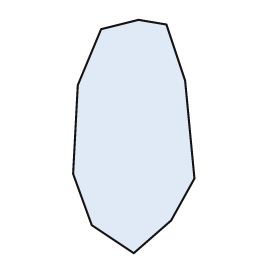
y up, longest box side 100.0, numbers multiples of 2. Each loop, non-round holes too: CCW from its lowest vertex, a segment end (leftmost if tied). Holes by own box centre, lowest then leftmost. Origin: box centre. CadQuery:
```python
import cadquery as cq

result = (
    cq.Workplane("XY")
    .moveTo(0.0, -50.0)
    .lineTo(16.0, -36.0)
    .lineTo(26.0, -18.0)
    .lineTo(22.0, 24.0)
    .lineTo(14.0, 48.0)
    .lineTo(2.0, 50.0)
    .lineTo(-14.0, 46.0)
    .lineTo(-24.0, 22.0)
    .lineTo(-26.0, -16.0)
    .lineTo(-18.0, -38.0)
    .close()
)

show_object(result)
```